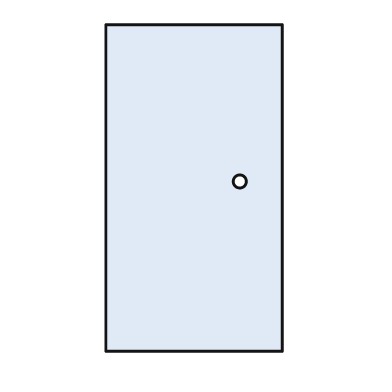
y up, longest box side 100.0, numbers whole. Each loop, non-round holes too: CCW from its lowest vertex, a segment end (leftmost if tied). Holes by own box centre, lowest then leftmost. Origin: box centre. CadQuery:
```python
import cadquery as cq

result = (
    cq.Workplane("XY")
    .moveTo(-27.0, -50.0)
    .lineTo(27.0, -50.0)
    .lineTo(27.0, 50.0)
    .lineTo(-27.0, 50.0)
    .close()
    .moveTo(14.0, 2.0)
    .circle(2.0)
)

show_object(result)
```